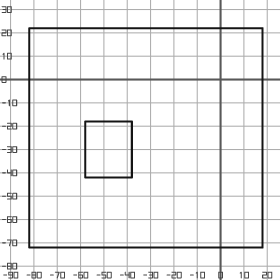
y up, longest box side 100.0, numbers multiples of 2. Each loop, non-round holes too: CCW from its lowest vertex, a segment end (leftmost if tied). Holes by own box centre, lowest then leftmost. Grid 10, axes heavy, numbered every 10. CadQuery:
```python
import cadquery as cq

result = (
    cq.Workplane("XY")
    .moveTo(-82.0, -72.0)
    .lineTo(18.0, -72.0)
    .lineTo(18.0, 22.0)
    .lineTo(-82.0, 22.0)
    .close()
    .moveTo(-58.0, -42.0)
    .lineTo(-38.0, -42.0)
    .lineTo(-38.0, -18.0)
    .lineTo(-58.0, -18.0)
    .close()
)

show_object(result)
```